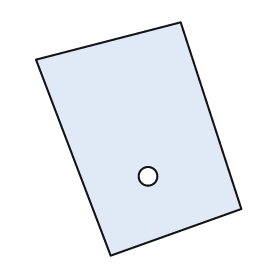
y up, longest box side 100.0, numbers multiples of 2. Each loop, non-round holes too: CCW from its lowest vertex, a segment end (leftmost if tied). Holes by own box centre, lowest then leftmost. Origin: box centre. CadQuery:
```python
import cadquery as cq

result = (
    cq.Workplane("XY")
    .moveTo(-12.0, -50.0)
    .lineTo(44.0, -30.0)
    .lineTo(18.0, 50.0)
    .lineTo(-44.0, 34.0)
    .close()
    .moveTo(4.0, -16.0)
    .circle(4.0)
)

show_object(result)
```